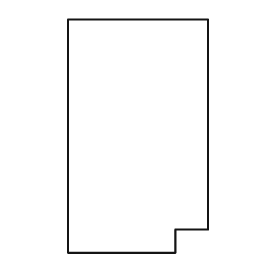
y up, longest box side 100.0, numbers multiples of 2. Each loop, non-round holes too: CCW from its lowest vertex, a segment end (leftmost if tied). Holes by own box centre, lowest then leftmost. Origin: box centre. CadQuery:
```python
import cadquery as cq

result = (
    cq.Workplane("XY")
    .moveTo(-30.0, -50.0)
    .lineTo(16.0, -50.0)
    .lineTo(16.0, -40.0)
    .lineTo(30.0, -40.0)
    .lineTo(30.0, 50.0)
    .lineTo(-30.0, 50.0)
    .close()
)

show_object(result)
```